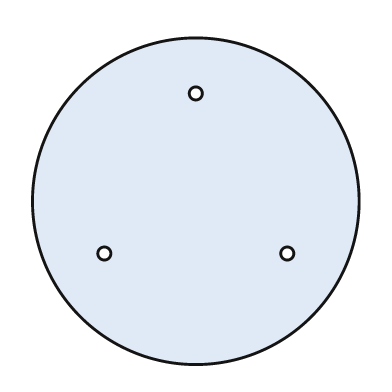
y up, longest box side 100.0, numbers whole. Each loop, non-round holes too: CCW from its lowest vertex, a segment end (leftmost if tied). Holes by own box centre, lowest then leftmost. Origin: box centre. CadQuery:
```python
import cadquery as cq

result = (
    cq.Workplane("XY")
    .moveTo(0.0, 0.0)
    .circle(50.0)
    .moveTo(-28.0, -16.0)
    .circle(2.0)
    .moveTo(28.0, -16.0)
    .circle(2.0)
    .moveTo(0.0, 33.0)
    .circle(2.0)
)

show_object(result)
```